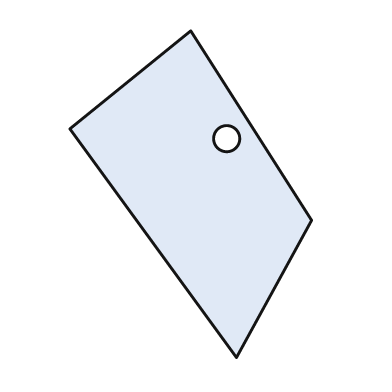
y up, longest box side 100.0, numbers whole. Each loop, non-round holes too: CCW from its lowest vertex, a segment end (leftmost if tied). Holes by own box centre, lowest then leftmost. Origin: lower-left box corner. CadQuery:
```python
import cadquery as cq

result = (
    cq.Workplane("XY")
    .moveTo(51.0, 0.0)
    .lineTo(74.0, 42.0)
    .lineTo(37.0, 100.0)
    .lineTo(0.0, 70.0)
    .close()
    .moveTo(48.0, 67.0)
    .circle(4.0)
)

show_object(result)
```